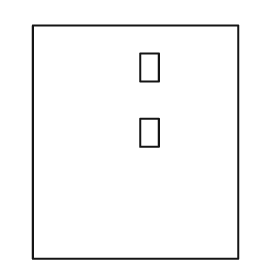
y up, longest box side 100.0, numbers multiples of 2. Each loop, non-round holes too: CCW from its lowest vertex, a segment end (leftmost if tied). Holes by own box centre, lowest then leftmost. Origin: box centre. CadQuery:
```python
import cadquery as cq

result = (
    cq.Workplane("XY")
    .moveTo(-44.0, -50.0)
    .lineTo(44.0, -50.0)
    .lineTo(44.0, 50.0)
    .lineTo(-44.0, 50.0)
    .close()
    .moveTo(2.0, -2.0)
    .lineTo(10.0, -2.0)
    .lineTo(10.0, 10.0)
    .lineTo(2.0, 10.0)
    .close()
    .moveTo(2.0, 26.0)
    .lineTo(10.0, 26.0)
    .lineTo(10.0, 38.0)
    .lineTo(2.0, 38.0)
    .close()
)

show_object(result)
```